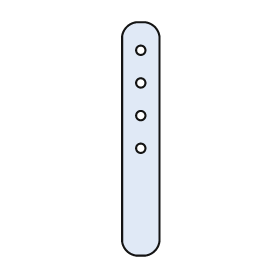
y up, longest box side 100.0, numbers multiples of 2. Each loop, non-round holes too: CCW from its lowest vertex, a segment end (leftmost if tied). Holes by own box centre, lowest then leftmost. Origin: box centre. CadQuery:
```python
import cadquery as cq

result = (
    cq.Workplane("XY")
    .moveTo(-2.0, -50.0)
    .lineTo(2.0, -50.0)
    .threePointArc((6.0, -48.0), (8.0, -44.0))
    .lineTo(8.0, 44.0)
    .threePointArc((6.0, 48.0), (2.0, 50.0))
    .lineTo(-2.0, 50.0)
    .threePointArc((-6.0, 48.0), (-8.0, 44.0))
    .lineTo(-8.0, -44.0)
    .threePointArc((-6.0, -48.0), (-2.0, -50.0))
    .close()
    .moveTo(0.0, -4.0)
    .circle(2.0)
    .moveTo(0.0, 10.0)
    .circle(2.0)
    .moveTo(0.0, 24.0)
    .circle(2.0)
    .moveTo(0.0, 38.0)
    .circle(2.0)
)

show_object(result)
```